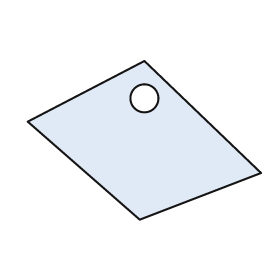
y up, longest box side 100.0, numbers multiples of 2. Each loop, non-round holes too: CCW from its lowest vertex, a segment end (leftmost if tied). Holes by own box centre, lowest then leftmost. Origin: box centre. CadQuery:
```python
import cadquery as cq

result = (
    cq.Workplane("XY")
    .moveTo(-2.0, -34.0)
    .lineTo(50.0, -14.0)
    .lineTo(0.0, 34.0)
    .lineTo(-50.0, 8.0)
    .close()
    .moveTo(0.0, 18.0)
    .circle(6.0)
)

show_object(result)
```